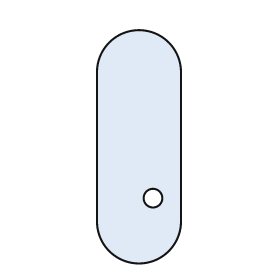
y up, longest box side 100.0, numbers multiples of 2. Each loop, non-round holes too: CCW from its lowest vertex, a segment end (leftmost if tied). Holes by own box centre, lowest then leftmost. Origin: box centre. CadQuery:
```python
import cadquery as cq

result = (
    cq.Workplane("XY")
    .moveTo(-18.0, -32.0)
    .threePointArc((0.0, -50.0), (18.0, -32.0))
    .lineTo(18.0, 32.0)
    .threePointArc((0.0, 50.0), (-18.0, 32.0))
    .close()
    .moveTo(6.0, -22.0)
    .circle(4.0)
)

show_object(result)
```